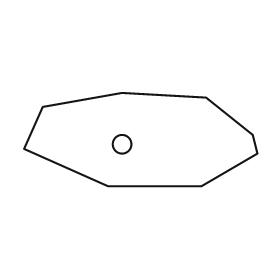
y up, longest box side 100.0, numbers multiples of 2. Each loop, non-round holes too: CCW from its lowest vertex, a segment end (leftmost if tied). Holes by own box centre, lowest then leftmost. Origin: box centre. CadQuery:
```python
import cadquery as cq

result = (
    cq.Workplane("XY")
    .moveTo(-14.0, -20.0)
    .lineTo(26.0, -20.0)
    .lineTo(50.0, -6.0)
    .lineTo(48.0, 2.0)
    .lineTo(28.0, 18.0)
    .lineTo(-8.0, 20.0)
    .lineTo(-42.0, 14.0)
    .lineTo(-50.0, -4.0)
    .close()
    .moveTo(-8.0, -2.0)
    .circle(4.0)
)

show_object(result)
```